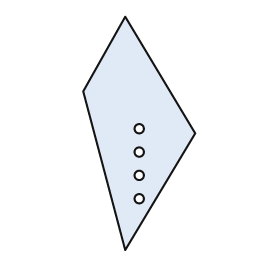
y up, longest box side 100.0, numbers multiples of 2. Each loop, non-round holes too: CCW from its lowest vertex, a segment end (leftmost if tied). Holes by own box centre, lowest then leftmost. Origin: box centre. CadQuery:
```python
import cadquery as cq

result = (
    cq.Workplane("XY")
    .moveTo(-6.0, -50.0)
    .lineTo(24.0, 0.0)
    .lineTo(-6.0, 50.0)
    .lineTo(-24.0, 18.0)
    .close()
    .moveTo(0.0, -28.0)
    .circle(2.0)
    .moveTo(0.0, -18.0)
    .circle(2.0)
    .moveTo(0.0, -8.0)
    .circle(2.0)
    .moveTo(0.0, 2.0)
    .circle(2.0)
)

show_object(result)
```